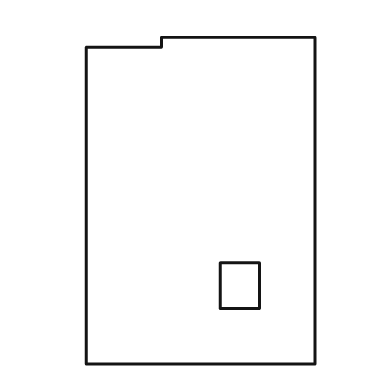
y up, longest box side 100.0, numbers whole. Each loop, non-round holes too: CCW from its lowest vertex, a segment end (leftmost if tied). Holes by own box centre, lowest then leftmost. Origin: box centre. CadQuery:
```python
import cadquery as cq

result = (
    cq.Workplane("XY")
    .moveTo(-35.0, -50.0)
    .lineTo(35.0, -50.0)
    .lineTo(35.0, 50.0)
    .lineTo(-12.0, 50.0)
    .lineTo(-12.0, 47.0)
    .lineTo(-35.0, 47.0)
    .close()
    .moveTo(6.0, -33.0)
    .lineTo(18.0, -33.0)
    .lineTo(18.0, -19.0)
    .lineTo(6.0, -19.0)
    .close()
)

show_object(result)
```